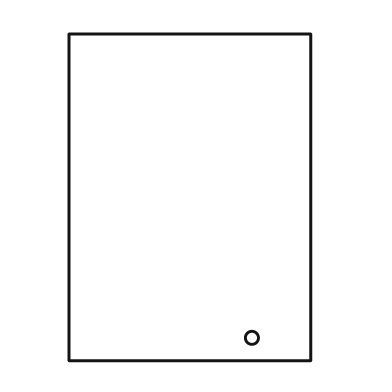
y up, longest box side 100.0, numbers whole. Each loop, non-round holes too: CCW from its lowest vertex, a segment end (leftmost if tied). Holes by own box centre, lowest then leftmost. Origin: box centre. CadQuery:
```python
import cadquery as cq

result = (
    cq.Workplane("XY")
    .moveTo(-37.0, -50.0)
    .lineTo(37.0, -50.0)
    .lineTo(37.0, 50.0)
    .lineTo(-37.0, 50.0)
    .close()
    .moveTo(19.0, -43.0)
    .circle(2.0)
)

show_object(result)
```